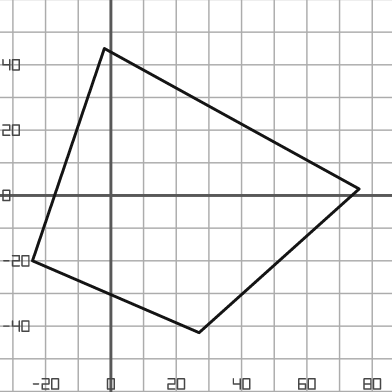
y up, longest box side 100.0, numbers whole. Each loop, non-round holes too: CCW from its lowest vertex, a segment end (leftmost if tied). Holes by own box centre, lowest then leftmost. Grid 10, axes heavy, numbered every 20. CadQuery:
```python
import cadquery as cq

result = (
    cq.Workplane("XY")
    .moveTo(27.0, -42.0)
    .lineTo(76.0, 2.0)
    .lineTo(-2.0, 45.0)
    .lineTo(-24.0, -20.0)
    .close()
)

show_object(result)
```